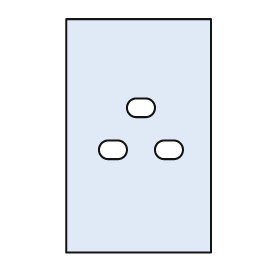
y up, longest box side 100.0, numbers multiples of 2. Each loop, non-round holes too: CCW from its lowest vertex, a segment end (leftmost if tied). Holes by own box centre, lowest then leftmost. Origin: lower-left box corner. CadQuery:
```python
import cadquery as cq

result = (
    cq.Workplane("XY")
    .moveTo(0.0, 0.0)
    .lineTo(62.0, 0.0)
    .lineTo(62.0, 100.0)
    .lineTo(0.0, 100.0)
    .close()
    .moveTo(18.0, 40.0)
    .lineTo(22.0, 40.0)
    .threePointArc((26.0, 44.0), (22.0, 48.0))
    .lineTo(18.0, 48.0)
    .threePointArc((14.0, 44.0), (18.0, 40.0))
    .close()
    .moveTo(42.0, 40.0)
    .lineTo(46.0, 40.0)
    .threePointArc((50.0, 44.0), (46.0, 48.0))
    .lineTo(42.0, 48.0)
    .threePointArc((38.0, 44.0), (42.0, 40.0))
    .close()
    .moveTo(30.0, 58.0)
    .lineTo(34.0, 58.0)
    .threePointArc((38.0, 62.0), (34.0, 66.0))
    .lineTo(30.0, 66.0)
    .threePointArc((26.0, 62.0), (30.0, 58.0))
    .close()
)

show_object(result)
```